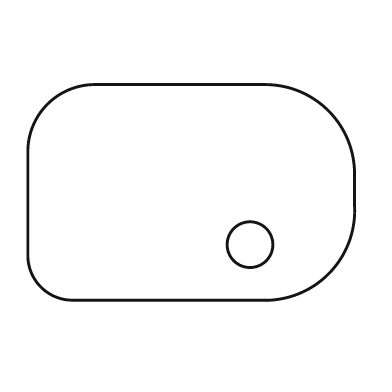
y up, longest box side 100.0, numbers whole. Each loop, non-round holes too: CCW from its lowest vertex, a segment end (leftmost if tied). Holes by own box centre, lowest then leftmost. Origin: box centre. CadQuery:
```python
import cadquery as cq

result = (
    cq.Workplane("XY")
    .moveTo(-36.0, -33.0)
    .lineTo(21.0, -33.0)
    .threePointArc((42.0, -25.0), (50.0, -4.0))
    .lineTo(50.0, 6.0)
    .threePointArc((42.0, 25.0), (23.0, 33.0))
    .lineTo(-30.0, 33.0)
    .threePointArc((-44.0, 27.0), (-50.0, 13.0))
    .lineTo(-50.0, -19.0)
    .threePointArc((-46.0, -29.0), (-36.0, -33.0))
    .close()
    .moveTo(18.0, -16.0)
    .circle(7.0)
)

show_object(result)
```